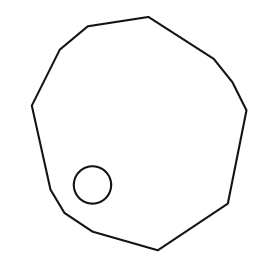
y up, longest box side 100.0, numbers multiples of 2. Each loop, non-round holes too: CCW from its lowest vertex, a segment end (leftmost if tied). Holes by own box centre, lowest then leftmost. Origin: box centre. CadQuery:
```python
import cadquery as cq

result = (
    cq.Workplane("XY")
    .moveTo(8.0, -50.0)
    .lineTo(38.0, -30.0)
    .lineTo(46.0, 10.0)
    .lineTo(40.0, 22.0)
    .lineTo(32.0, 32.0)
    .lineTo(4.0, 50.0)
    .lineTo(-22.0, 46.0)
    .lineTo(-34.0, 36.0)
    .lineTo(-46.0, 12.0)
    .lineTo(-38.0, -24.0)
    .lineTo(-32.0, -34.0)
    .lineTo(-20.0, -42.0)
    .close()
    .moveTo(-20.0, -22.0)
    .circle(8.0)
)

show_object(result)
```